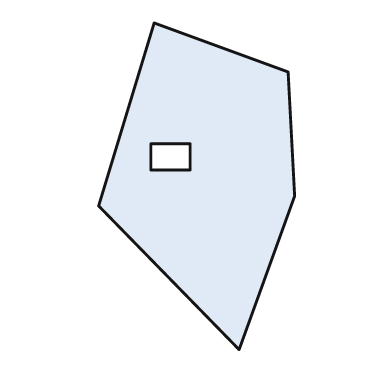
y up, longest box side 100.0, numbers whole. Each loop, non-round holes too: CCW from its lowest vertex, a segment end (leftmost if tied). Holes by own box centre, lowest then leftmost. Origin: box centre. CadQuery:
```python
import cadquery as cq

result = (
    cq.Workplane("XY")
    .moveTo(13.0, -50.0)
    .lineTo(30.0, -3.0)
    .lineTo(28.0, 35.0)
    .lineTo(-13.0, 50.0)
    .lineTo(-30.0, -6.0)
    .close()
    .moveTo(-14.0, 5.0)
    .lineTo(-2.0, 5.0)
    .lineTo(-2.0, 13.0)
    .lineTo(-14.0, 13.0)
    .close()
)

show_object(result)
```